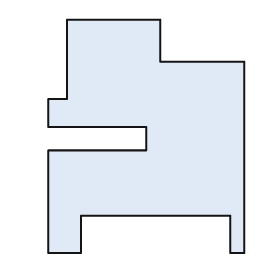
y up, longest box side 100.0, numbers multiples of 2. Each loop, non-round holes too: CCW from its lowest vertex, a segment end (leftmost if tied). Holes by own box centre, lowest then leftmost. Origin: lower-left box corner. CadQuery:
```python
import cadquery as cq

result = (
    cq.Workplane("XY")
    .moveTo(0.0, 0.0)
    .lineTo(14.0, 0.0)
    .lineTo(14.0, 16.0)
    .lineTo(78.0, 16.0)
    .lineTo(78.0, 0.0)
    .lineTo(84.0, 0.0)
    .lineTo(84.0, 82.0)
    .lineTo(48.0, 82.0)
    .lineTo(48.0, 100.0)
    .lineTo(8.0, 100.0)
    .lineTo(8.0, 66.0)
    .lineTo(0.0, 66.0)
    .lineTo(0.0, 54.0)
    .lineTo(42.0, 54.0)
    .lineTo(42.0, 44.0)
    .lineTo(0.0, 44.0)
    .close()
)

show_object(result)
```